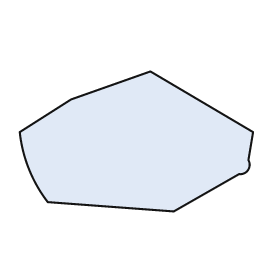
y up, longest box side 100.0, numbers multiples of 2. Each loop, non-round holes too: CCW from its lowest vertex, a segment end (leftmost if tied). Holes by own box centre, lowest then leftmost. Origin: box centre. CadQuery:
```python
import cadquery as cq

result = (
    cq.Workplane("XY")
    .moveTo(16.0, -30.0)
    .lineTo(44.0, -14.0)
    .threePointArc((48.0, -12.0), (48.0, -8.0))
    .lineTo(50.0, 4.0)
    .lineTo(6.0, 30.0)
    .lineTo(-28.0, 18.0)
    .lineTo(-50.0, 4.0)
    .threePointArc((-46.0, -12.0), (-38.0, -26.0))
    .close()
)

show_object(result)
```